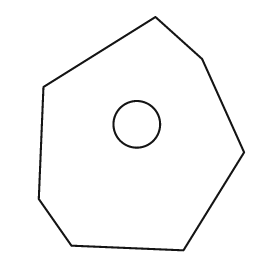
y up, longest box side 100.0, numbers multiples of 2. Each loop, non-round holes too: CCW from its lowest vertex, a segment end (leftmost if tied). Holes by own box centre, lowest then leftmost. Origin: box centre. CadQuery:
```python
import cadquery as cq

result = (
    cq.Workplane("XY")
    .moveTo(18.0, -50.0)
    .lineTo(44.0, -8.0)
    .lineTo(26.0, 32.0)
    .lineTo(6.0, 50.0)
    .lineTo(-42.0, 20.0)
    .lineTo(-44.0, -28.0)
    .lineTo(-30.0, -48.0)
    .close()
    .moveTo(-2.0, 4.0)
    .circle(10.0)
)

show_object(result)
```